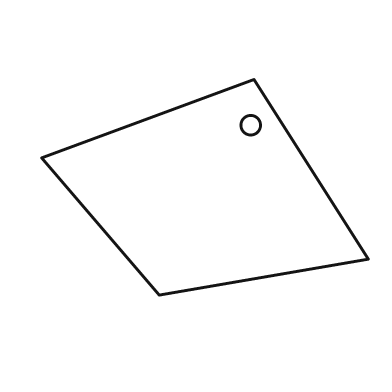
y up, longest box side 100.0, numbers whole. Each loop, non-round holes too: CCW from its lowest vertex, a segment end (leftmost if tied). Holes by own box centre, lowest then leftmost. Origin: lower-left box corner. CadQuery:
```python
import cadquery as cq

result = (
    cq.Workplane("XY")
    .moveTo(36.0, 0.0)
    .lineTo(100.0, 11.0)
    .lineTo(65.0, 66.0)
    .lineTo(0.0, 42.0)
    .close()
    .moveTo(64.0, 52.0)
    .circle(3.0)
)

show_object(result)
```